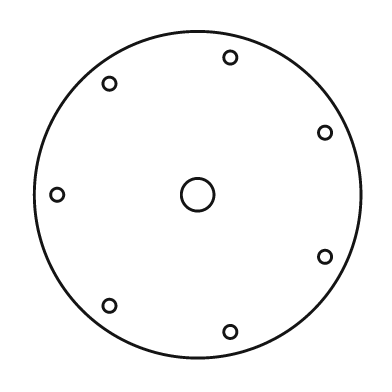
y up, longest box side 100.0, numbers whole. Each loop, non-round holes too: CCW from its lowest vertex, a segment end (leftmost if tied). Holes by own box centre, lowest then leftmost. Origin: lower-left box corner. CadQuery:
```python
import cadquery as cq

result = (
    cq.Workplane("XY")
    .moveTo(50.0, 50.0)
    .circle(50.0)
    .moveTo(60.0, 8.0)
    .circle(2.0)
    .moveTo(23.0, 16.0)
    .circle(2.0)
    .moveTo(89.0, 31.0)
    .circle(2.0)
    .moveTo(7.0, 50.0)
    .circle(2.0)
    .moveTo(50.0, 50.0)
    .circle(5.0)
    .moveTo(89.0, 69.0)
    .circle(2.0)
    .moveTo(23.0, 84.0)
    .circle(2.0)
    .moveTo(60.0, 92.0)
    .circle(2.0)
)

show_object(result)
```